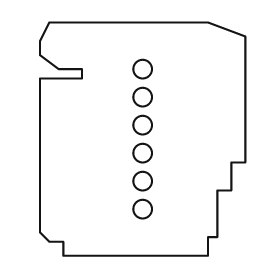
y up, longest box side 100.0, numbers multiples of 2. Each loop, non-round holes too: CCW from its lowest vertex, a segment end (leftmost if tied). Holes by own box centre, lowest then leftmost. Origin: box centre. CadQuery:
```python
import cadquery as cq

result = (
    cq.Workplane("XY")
    .moveTo(-34.0, -50.0)
    .lineTo(28.0, -50.0)
    .lineTo(28.0, -42.0)
    .lineTo(32.0, -42.0)
    .lineTo(32.0, -22.0)
    .lineTo(38.0, -22.0)
    .lineTo(38.0, -10.0)
    .lineTo(44.0, -10.0)
    .lineTo(44.0, 44.0)
    .lineTo(28.0, 50.0)
    .lineTo(-40.0, 50.0)
    .lineTo(-44.0, 42.0)
    .lineTo(-44.0, 36.0)
    .lineTo(-36.0, 30.0)
    .lineTo(-26.0, 30.0)
    .lineTo(-26.0, 26.0)
    .lineTo(-44.0, 26.0)
    .lineTo(-44.0, -40.0)
    .lineTo(-40.0, -44.0)
    .lineTo(-34.0, -44.0)
    .close()
    .moveTo(0.0, -30.0)
    .circle(4.0)
    .moveTo(0.0, -18.0)
    .circle(4.0)
    .moveTo(0.0, -6.0)
    .circle(4.0)
    .moveTo(0.0, 6.0)
    .circle(4.0)
    .moveTo(0.0, 18.0)
    .circle(4.0)
    .moveTo(0.0, 30.0)
    .circle(4.0)
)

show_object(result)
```